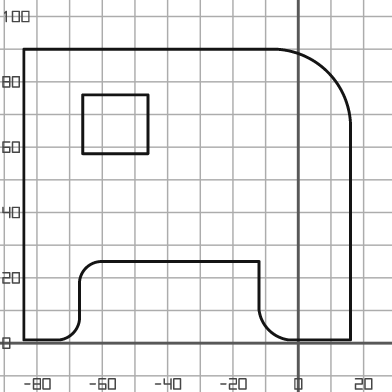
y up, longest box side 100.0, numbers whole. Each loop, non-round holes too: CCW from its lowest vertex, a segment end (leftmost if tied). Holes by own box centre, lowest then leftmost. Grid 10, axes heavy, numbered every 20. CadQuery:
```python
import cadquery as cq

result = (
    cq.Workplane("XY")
    .moveTo(-84.0, 1.0)
    .lineTo(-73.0, 1.0)
    .threePointArc((-69.0, 3.0), (-67.0, 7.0))
    .lineTo(-67.0, 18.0)
    .threePointArc((-65.0, 23.0), (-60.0, 25.0))
    .lineTo(-12.0, 25.0)
    .lineTo(-12.0, 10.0)
    .threePointArc((-9.0, 4.0), (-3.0, 1.0))
    .lineTo(16.0, 1.0)
    .lineTo(16.0, 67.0)
    .threePointArc((9.0, 83.0), (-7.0, 90.0))
    .lineTo(-84.0, 90.0)
    .close()
    .moveTo(-66.0, 58.0)
    .lineTo(-46.0, 58.0)
    .lineTo(-46.0, 76.0)
    .lineTo(-66.0, 76.0)
    .close()
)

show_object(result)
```